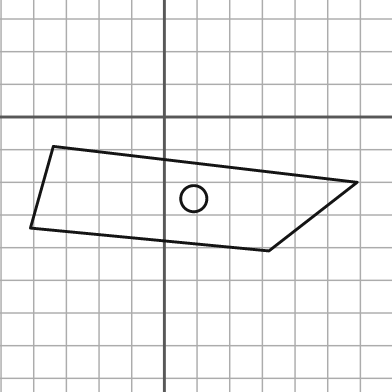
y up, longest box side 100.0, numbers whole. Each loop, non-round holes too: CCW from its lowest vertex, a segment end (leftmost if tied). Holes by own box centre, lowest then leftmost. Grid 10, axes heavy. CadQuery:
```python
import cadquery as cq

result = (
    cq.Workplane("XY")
    .moveTo(32.0, -41.0)
    .lineTo(59.0, -20.0)
    .lineTo(-34.0, -9.0)
    .lineTo(-41.0, -34.0)
    .close()
    .moveTo(9.0, -25.0)
    .circle(4.0)
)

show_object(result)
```